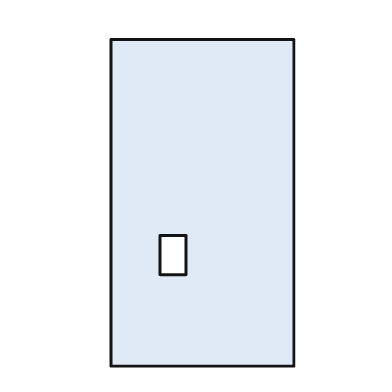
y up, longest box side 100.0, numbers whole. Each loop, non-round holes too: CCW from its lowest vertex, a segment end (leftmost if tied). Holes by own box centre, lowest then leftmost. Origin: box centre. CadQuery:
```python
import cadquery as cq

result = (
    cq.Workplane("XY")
    .moveTo(-28.0, -50.0)
    .lineTo(28.0, -50.0)
    .lineTo(28.0, 50.0)
    .lineTo(-28.0, 50.0)
    .close()
    .moveTo(-13.0, -22.0)
    .lineTo(-5.0, -22.0)
    .lineTo(-5.0, -10.0)
    .lineTo(-13.0, -10.0)
    .close()
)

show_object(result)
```